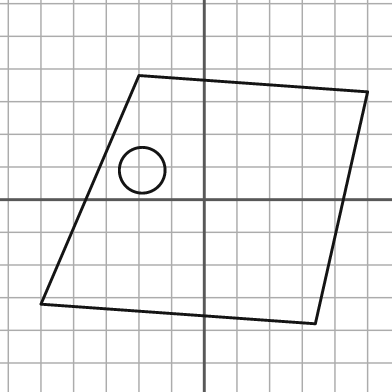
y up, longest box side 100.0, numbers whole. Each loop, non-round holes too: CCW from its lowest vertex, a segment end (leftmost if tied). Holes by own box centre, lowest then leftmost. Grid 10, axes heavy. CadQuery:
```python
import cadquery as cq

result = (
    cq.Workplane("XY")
    .moveTo(34.0, -38.0)
    .lineTo(50.0, 33.0)
    .lineTo(-20.0, 38.0)
    .lineTo(-50.0, -32.0)
    .close()
    .moveTo(-19.0, 9.0)
    .circle(7.0)
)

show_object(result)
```